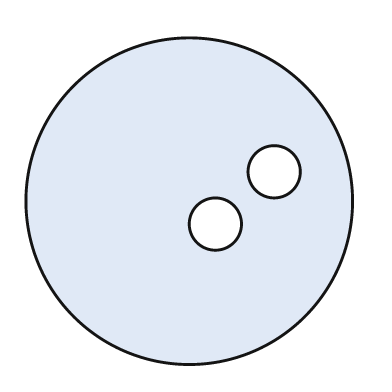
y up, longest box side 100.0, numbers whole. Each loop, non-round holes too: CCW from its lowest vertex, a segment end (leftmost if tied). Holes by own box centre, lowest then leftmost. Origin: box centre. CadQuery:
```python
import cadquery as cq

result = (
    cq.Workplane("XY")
    .moveTo(0.0, 0.0)
    .circle(50.0)
    .moveTo(8.0, -7.0)
    .circle(8.0)
    .moveTo(26.0, 9.0)
    .circle(8.0)
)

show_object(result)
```